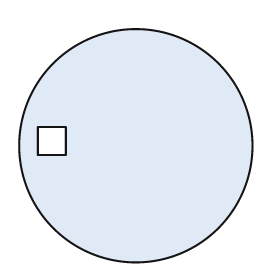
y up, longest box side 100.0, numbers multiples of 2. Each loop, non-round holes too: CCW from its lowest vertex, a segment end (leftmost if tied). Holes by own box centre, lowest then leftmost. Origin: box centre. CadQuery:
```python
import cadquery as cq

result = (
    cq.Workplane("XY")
    .moveTo(0.0, 0.0)
    .circle(50.0)
    .moveTo(-42.0, -4.0)
    .lineTo(-30.0, -4.0)
    .lineTo(-30.0, 8.0)
    .lineTo(-42.0, 8.0)
    .close()
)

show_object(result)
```